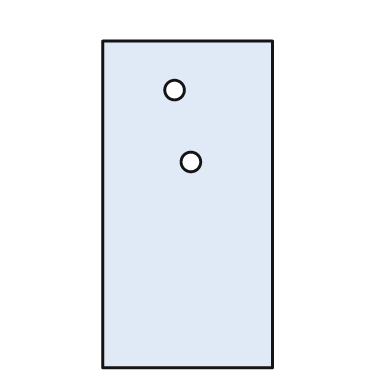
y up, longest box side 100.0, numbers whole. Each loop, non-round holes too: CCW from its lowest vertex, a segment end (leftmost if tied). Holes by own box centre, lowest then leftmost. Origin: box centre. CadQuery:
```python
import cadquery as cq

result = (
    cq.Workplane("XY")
    .moveTo(-26.0, -50.0)
    .lineTo(26.0, -50.0)
    .lineTo(26.0, 50.0)
    .lineTo(-26.0, 50.0)
    .close()
    .moveTo(1.0, 13.0)
    .circle(3.0)
    .moveTo(-4.0, 35.0)
    .circle(3.0)
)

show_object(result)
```